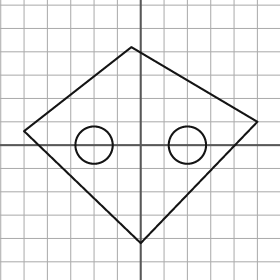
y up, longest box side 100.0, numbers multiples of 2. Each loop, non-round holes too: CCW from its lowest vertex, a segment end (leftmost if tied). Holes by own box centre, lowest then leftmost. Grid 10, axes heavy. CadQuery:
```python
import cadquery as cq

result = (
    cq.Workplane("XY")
    .moveTo(0.0, -42.0)
    .lineTo(50.0, 10.0)
    .lineTo(-4.0, 42.0)
    .lineTo(-50.0, 6.0)
    .close()
    .moveTo(-20.0, 0.0)
    .circle(8.0)
    .moveTo(20.0, 0.0)
    .circle(8.0)
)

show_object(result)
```